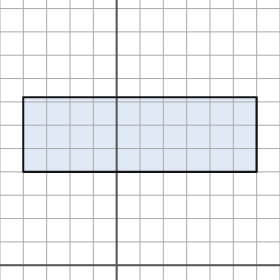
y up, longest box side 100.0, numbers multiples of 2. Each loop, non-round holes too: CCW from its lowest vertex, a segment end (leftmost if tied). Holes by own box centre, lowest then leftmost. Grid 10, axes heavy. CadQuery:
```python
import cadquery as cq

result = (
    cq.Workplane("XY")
    .moveTo(-40.0, 40.0)
    .lineTo(60.0, 40.0)
    .lineTo(60.0, 72.0)
    .lineTo(-40.0, 72.0)
    .close()
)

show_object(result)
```